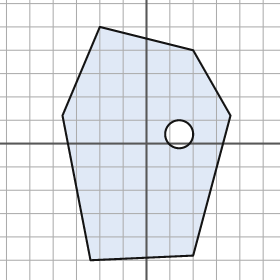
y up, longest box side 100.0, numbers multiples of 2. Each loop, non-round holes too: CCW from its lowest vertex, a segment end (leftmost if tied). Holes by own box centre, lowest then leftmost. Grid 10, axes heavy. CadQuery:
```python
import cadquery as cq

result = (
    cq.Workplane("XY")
    .moveTo(-24.0, -50.0)
    .lineTo(20.0, -48.0)
    .lineTo(36.0, 12.0)
    .lineTo(20.0, 40.0)
    .lineTo(-20.0, 50.0)
    .lineTo(-36.0, 12.0)
    .close()
    .moveTo(14.0, 4.0)
    .circle(6.0)
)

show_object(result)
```